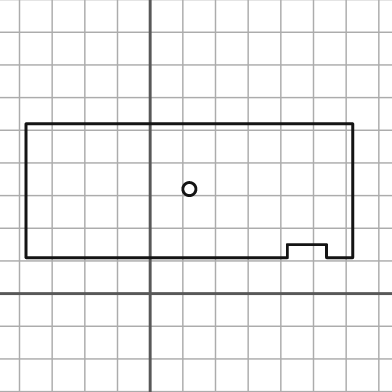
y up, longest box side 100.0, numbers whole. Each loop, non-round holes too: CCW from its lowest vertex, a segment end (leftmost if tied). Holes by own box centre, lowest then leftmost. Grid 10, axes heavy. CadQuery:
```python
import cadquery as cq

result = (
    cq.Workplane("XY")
    .moveTo(-38.0, 11.0)
    .lineTo(42.0, 11.0)
    .lineTo(42.0, 15.0)
    .lineTo(54.0, 15.0)
    .lineTo(54.0, 11.0)
    .lineTo(62.0, 11.0)
    .lineTo(62.0, 52.0)
    .lineTo(-38.0, 52.0)
    .close()
    .moveTo(12.0, 32.0)
    .circle(2.0)
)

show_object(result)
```